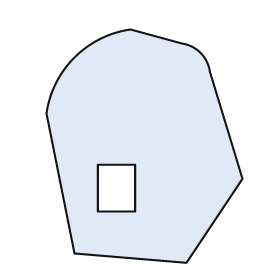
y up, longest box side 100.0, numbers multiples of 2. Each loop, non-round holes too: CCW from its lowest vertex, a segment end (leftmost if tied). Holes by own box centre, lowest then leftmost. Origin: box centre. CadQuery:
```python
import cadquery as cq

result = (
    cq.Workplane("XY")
    .moveTo(18.0, -50.0)
    .lineTo(42.0, -14.0)
    .lineTo(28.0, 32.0)
    .threePointArc((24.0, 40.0), (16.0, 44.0))
    .lineTo(-6.0, 50.0)
    .threePointArc((-30.0, 38.0), (-42.0, 14.0))
    .lineTo(-30.0, -46.0)
    .close()
    .moveTo(-20.0, -28.0)
    .lineTo(-4.0, -28.0)
    .lineTo(-4.0, -8.0)
    .lineTo(-20.0, -8.0)
    .close()
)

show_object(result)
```